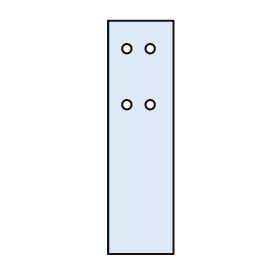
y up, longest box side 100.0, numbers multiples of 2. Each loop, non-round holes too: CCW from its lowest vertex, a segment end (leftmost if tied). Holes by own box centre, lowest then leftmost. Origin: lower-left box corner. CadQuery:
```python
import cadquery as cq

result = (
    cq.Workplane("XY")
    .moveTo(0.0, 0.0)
    .lineTo(28.0, 0.0)
    .lineTo(28.0, 100.0)
    .lineTo(0.0, 100.0)
    .close()
    .moveTo(8.0, 64.0)
    .circle(2.0)
    .moveTo(18.0, 64.0)
    .circle(2.0)
    .moveTo(8.0, 88.0)
    .circle(2.0)
    .moveTo(18.0, 88.0)
    .circle(2.0)
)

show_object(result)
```